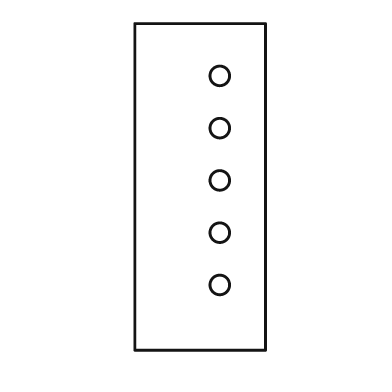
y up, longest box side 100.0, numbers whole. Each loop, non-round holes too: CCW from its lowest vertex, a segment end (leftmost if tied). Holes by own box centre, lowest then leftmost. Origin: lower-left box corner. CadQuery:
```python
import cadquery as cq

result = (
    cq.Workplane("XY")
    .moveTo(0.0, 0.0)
    .lineTo(40.0, 0.0)
    .lineTo(40.0, 100.0)
    .lineTo(0.0, 100.0)
    .close()
    .moveTo(26.0, 20.0)
    .circle(3.0)
    .moveTo(26.0, 36.0)
    .circle(3.0)
    .moveTo(26.0, 52.0)
    .circle(3.0)
    .moveTo(26.0, 68.0)
    .circle(3.0)
    .moveTo(26.0, 84.0)
    .circle(3.0)
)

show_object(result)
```